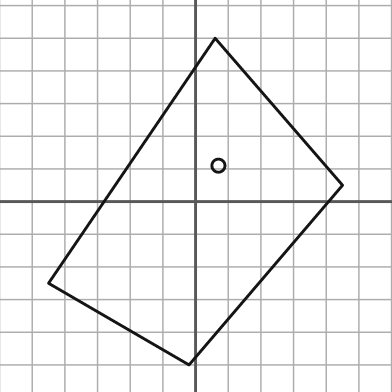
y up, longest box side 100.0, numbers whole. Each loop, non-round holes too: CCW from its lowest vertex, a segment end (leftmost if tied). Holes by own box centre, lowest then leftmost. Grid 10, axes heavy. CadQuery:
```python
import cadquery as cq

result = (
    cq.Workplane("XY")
    .moveTo(-2.0, -50.0)
    .lineTo(45.0, 5.0)
    .lineTo(6.0, 50.0)
    .lineTo(-45.0, -25.0)
    .close()
    .moveTo(7.0, 11.0)
    .circle(2.0)
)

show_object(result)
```